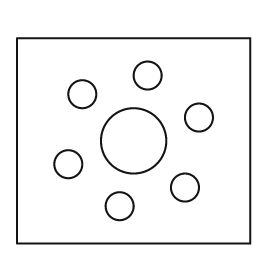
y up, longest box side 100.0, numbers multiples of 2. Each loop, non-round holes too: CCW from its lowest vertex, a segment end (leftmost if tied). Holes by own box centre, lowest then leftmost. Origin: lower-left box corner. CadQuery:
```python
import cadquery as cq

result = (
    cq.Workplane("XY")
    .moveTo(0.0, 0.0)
    .lineTo(100.0, 0.0)
    .lineTo(100.0, 88.0)
    .lineTo(0.0, 88.0)
    .close()
    .moveTo(44.0, 16.0)
    .circle(6.0)
    .moveTo(72.0, 24.0)
    .circle(6.0)
    .moveTo(22.0, 34.0)
    .circle(6.0)
    .moveTo(50.0, 44.0)
    .circle(14.0)
    .moveTo(78.0, 54.0)
    .circle(6.0)
    .moveTo(28.0, 64.0)
    .circle(6.0)
    .moveTo(56.0, 72.0)
    .circle(6.0)
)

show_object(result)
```